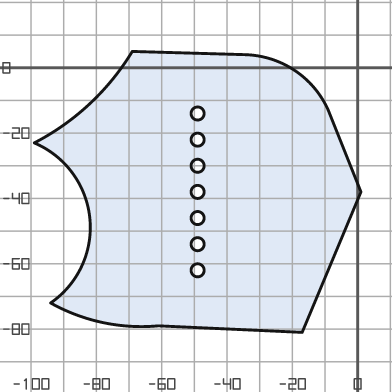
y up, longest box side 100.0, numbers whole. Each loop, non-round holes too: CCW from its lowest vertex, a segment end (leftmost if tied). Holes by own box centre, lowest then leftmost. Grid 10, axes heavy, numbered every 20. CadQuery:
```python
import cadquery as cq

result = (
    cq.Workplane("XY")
    .moveTo(-17.0, -81.0)
    .lineTo(1.0, -38.0)
    .lineTo(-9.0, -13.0)
    .threePointArc((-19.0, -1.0), (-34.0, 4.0))
    .lineTo(-69.0, 5.0)
    .threePointArc((-82.0, -11.0), (-99.0, -23.0))
    .threePointArc((-82.0, -46.0), (-94.0, -72.0))
    .threePointArc((-78.0, -78.0), (-61.0, -79.0))
    .close()
    .moveTo(-49.0, -62.0)
    .circle(2.0)
    .moveTo(-49.0, -54.0)
    .circle(2.0)
    .moveTo(-49.0, -46.0)
    .circle(2.0)
    .moveTo(-49.0, -38.0)
    .circle(2.0)
    .moveTo(-49.0, -30.0)
    .circle(2.0)
    .moveTo(-49.0, -22.0)
    .circle(2.0)
    .moveTo(-49.0, -14.0)
    .circle(2.0)
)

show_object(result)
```